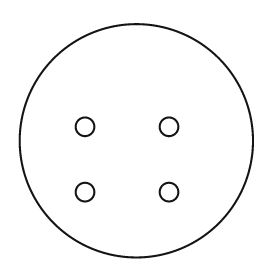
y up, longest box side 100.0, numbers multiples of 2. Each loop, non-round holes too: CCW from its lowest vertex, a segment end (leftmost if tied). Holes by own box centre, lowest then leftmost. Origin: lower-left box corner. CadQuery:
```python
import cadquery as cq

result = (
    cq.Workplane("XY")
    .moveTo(50.0, 50.0)
    .circle(50.0)
    .moveTo(28.0, 28.0)
    .circle(4.0)
    .moveTo(64.0, 28.0)
    .circle(4.0)
    .moveTo(28.0, 56.0)
    .circle(4.0)
    .moveTo(64.0, 56.0)
    .circle(4.0)
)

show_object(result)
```